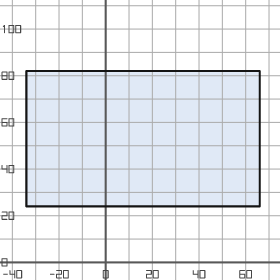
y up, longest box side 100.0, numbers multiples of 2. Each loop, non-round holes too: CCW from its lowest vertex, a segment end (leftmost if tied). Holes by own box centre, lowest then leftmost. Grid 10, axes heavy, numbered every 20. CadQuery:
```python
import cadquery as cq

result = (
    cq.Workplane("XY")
    .moveTo(-34.0, 24.0)
    .lineTo(66.0, 24.0)
    .lineTo(66.0, 82.0)
    .lineTo(-34.0, 82.0)
    .close()
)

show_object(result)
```